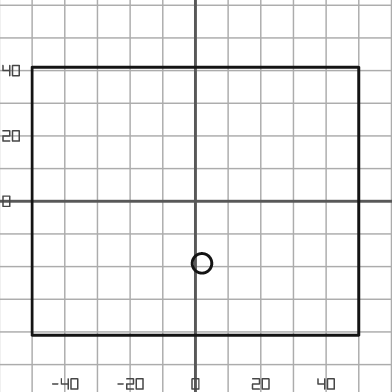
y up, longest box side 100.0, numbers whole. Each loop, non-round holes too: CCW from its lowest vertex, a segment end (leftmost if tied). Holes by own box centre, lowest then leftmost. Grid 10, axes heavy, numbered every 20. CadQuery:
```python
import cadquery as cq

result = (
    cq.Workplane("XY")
    .moveTo(-50.0, -41.0)
    .lineTo(50.0, -41.0)
    .lineTo(50.0, 41.0)
    .lineTo(-50.0, 41.0)
    .close()
    .moveTo(2.0, -19.0)
    .circle(3.0)
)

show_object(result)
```